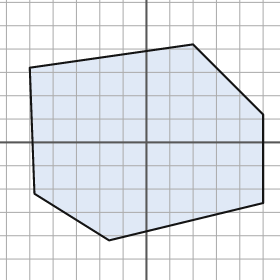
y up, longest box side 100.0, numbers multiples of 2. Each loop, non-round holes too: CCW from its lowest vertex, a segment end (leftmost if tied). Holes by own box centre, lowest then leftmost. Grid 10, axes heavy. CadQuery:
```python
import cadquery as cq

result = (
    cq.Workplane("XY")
    .moveTo(-16.0, -42.0)
    .lineTo(50.0, -26.0)
    .lineTo(50.0, 12.0)
    .lineTo(20.0, 42.0)
    .lineTo(-50.0, 32.0)
    .lineTo(-48.0, -22.0)
    .close()
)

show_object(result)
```